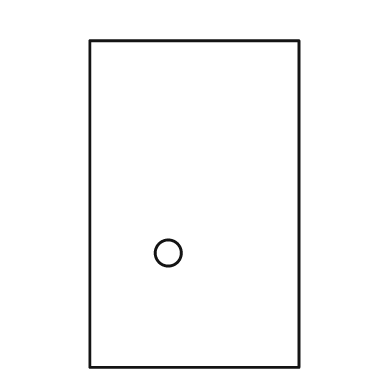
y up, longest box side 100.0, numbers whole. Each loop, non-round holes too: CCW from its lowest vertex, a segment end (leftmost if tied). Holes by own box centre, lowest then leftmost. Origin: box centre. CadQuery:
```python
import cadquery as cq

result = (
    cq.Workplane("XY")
    .moveTo(-32.0, -50.0)
    .lineTo(32.0, -50.0)
    .lineTo(32.0, 50.0)
    .lineTo(-32.0, 50.0)
    .close()
    .moveTo(-8.0, -15.0)
    .circle(4.0)
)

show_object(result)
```